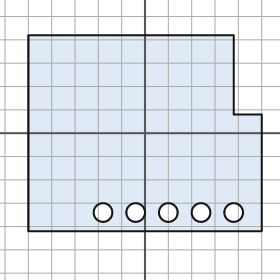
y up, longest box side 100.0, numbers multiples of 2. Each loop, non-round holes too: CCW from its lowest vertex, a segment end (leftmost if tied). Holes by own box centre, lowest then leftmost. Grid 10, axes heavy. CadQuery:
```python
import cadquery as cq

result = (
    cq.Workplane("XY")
    .moveTo(-50.0, -42.0)
    .lineTo(50.0, -42.0)
    .lineTo(50.0, 8.0)
    .lineTo(38.0, 8.0)
    .lineTo(38.0, 42.0)
    .lineTo(-50.0, 42.0)
    .close()
    .moveTo(-18.0, -34.0)
    .circle(4.0)
    .moveTo(-4.0, -34.0)
    .circle(4.0)
    .moveTo(10.0, -34.0)
    .circle(4.0)
    .moveTo(24.0, -34.0)
    .circle(4.0)
    .moveTo(38.0, -34.0)
    .circle(4.0)
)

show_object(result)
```